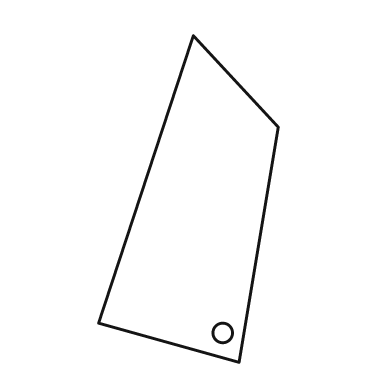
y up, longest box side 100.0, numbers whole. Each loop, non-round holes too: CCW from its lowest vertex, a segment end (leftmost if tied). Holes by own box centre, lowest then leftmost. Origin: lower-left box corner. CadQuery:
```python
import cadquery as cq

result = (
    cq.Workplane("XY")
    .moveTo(43.0, 0.0)
    .lineTo(55.0, 72.0)
    .lineTo(29.0, 100.0)
    .lineTo(0.0, 12.0)
    .close()
    .moveTo(38.0, 9.0)
    .circle(3.0)
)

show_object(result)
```